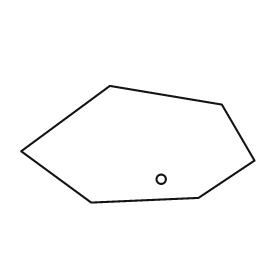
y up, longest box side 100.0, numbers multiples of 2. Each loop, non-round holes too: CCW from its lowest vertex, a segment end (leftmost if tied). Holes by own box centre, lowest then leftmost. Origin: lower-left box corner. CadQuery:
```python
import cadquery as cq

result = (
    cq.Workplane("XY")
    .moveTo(30.0, 0.0)
    .lineTo(76.0, 2.0)
    .lineTo(100.0, 18.0)
    .lineTo(86.0, 42.0)
    .lineTo(38.0, 50.0)
    .lineTo(0.0, 22.0)
    .close()
    .moveTo(60.0, 10.0)
    .circle(2.0)
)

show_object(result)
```